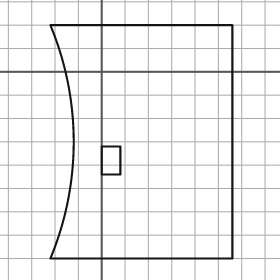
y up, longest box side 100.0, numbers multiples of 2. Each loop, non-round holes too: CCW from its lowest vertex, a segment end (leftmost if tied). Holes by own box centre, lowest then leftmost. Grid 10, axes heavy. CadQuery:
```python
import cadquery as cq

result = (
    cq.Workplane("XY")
    .moveTo(-22.0, -80.0)
    .lineTo(56.0, -80.0)
    .lineTo(56.0, 20.0)
    .lineTo(-22.0, 20.0)
    .threePointArc((-12.0, -30.0), (-22.0, -80.0))
    .close()
    .moveTo(0.0, -44.0)
    .lineTo(8.0, -44.0)
    .lineTo(8.0, -32.0)
    .lineTo(0.0, -32.0)
    .close()
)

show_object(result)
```